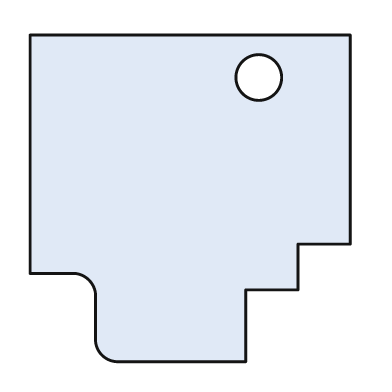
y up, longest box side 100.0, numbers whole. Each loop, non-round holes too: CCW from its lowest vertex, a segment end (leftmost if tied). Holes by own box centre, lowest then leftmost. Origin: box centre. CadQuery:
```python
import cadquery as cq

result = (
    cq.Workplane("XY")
    .moveTo(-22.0, -50.0)
    .lineTo(17.0, -50.0)
    .lineTo(17.0, -28.0)
    .lineTo(33.0, -28.0)
    .lineTo(33.0, -14.0)
    .lineTo(49.0, -14.0)
    .lineTo(49.0, 50.0)
    .lineTo(-49.0, 50.0)
    .lineTo(-49.0, -23.0)
    .lineTo(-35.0, -23.0)
    .threePointArc((-31.0, -25.0), (-29.0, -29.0))
    .lineTo(-29.0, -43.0)
    .threePointArc((-27.0, -48.0), (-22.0, -50.0))
    .close()
    .moveTo(21.0, 37.0)
    .circle(7.0)
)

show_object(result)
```